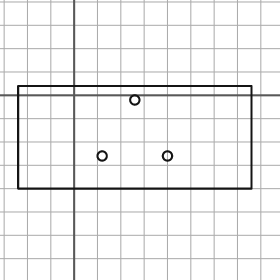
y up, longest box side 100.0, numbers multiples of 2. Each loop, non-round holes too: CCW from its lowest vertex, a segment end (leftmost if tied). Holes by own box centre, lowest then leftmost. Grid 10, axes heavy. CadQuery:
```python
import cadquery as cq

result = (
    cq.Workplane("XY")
    .moveTo(-24.0, -40.0)
    .lineTo(76.0, -40.0)
    .lineTo(76.0, 4.0)
    .lineTo(-24.0, 4.0)
    .close()
    .moveTo(12.0, -26.0)
    .circle(2.0)
    .moveTo(40.0, -26.0)
    .circle(2.0)
    .moveTo(26.0, -2.0)
    .circle(2.0)
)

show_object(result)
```